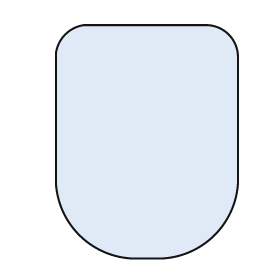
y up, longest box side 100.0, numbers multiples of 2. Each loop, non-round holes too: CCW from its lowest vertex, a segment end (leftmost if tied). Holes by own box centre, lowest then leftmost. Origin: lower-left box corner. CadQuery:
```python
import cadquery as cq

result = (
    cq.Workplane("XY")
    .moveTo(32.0, 0.0)
    .lineTo(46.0, 0.0)
    .threePointArc((68.0, 10.0), (78.0, 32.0))
    .lineTo(78.0, 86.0)
    .threePointArc((74.0, 96.0), (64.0, 100.0))
    .lineTo(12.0, 100.0)
    .threePointArc((4.0, 96.0), (0.0, 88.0))
    .lineTo(0.0, 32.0)
    .threePointArc((10.0, 10.0), (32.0, 0.0))
    .close()
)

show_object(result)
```